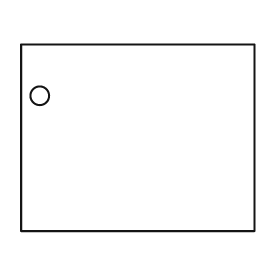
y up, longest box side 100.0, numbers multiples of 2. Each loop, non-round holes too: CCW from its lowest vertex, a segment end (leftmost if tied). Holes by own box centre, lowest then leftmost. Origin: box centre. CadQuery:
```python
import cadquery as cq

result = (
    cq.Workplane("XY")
    .moveTo(-50.0, -40.0)
    .lineTo(50.0, -40.0)
    .lineTo(50.0, 40.0)
    .lineTo(-50.0, 40.0)
    .close()
    .moveTo(-42.0, 18.0)
    .circle(4.0)
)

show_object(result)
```